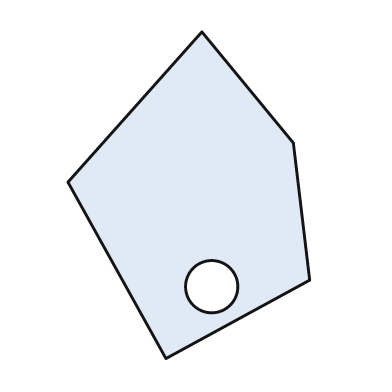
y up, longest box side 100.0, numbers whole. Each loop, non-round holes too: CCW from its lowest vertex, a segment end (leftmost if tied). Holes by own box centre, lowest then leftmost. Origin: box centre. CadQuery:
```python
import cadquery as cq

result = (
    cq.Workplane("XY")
    .moveTo(-7.0, -50.0)
    .lineTo(37.0, -26.0)
    .lineTo(32.0, 16.0)
    .lineTo(4.0, 50.0)
    .lineTo(-37.0, 4.0)
    .close()
    .moveTo(7.0, -28.0)
    .circle(8.0)
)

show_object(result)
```